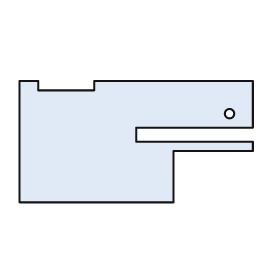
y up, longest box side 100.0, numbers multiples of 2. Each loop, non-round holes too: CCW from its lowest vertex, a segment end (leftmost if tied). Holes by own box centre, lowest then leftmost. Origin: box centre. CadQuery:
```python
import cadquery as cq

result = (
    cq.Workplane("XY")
    .moveTo(-50.0, -26.0)
    .lineTo(16.0, -26.0)
    .lineTo(16.0, -4.0)
    .lineTo(50.0, -4.0)
    .lineTo(50.0, 0.0)
    .lineTo(0.0, 0.0)
    .lineTo(0.0, 6.0)
    .lineTo(50.0, 6.0)
    .lineTo(50.0, 26.0)
    .lineTo(-18.0, 26.0)
    .lineTo(-18.0, 22.0)
    .lineTo(-42.0, 22.0)
    .lineTo(-42.0, 26.0)
    .lineTo(-50.0, 26.0)
    .close()
    .moveTo(40.0, 12.0)
    .circle(2.0)
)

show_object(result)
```